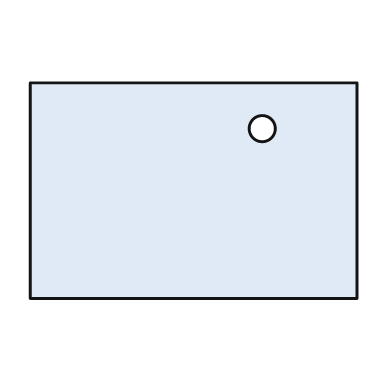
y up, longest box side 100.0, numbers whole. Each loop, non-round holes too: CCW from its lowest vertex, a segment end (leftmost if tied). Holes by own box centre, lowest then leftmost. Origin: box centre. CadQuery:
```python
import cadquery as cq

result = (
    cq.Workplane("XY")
    .moveTo(-50.0, -33.0)
    .lineTo(50.0, -33.0)
    .lineTo(50.0, 33.0)
    .lineTo(-50.0, 33.0)
    .close()
    .moveTo(21.0, 19.0)
    .circle(4.0)
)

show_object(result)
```